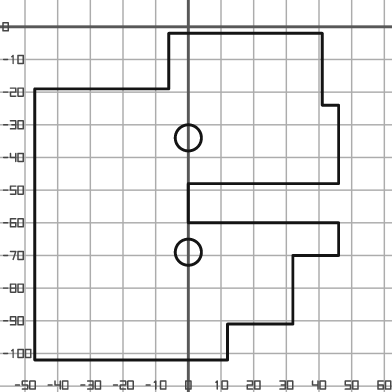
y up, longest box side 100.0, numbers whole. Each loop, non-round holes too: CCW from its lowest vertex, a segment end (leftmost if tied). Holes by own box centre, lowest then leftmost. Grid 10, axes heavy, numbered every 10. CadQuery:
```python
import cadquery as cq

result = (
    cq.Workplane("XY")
    .moveTo(-47.0, -102.0)
    .lineTo(12.0, -102.0)
    .lineTo(12.0, -91.0)
    .lineTo(32.0, -91.0)
    .lineTo(32.0, -70.0)
    .lineTo(46.0, -70.0)
    .lineTo(46.0, -60.0)
    .lineTo(0.0, -60.0)
    .lineTo(0.0, -48.0)
    .lineTo(46.0, -48.0)
    .lineTo(46.0, -24.0)
    .lineTo(41.0, -24.0)
    .lineTo(41.0, -2.0)
    .lineTo(-6.0, -2.0)
    .lineTo(-6.0, -19.0)
    .lineTo(-47.0, -19.0)
    .close()
    .moveTo(0.0, -69.0)
    .circle(4.0)
    .moveTo(0.0, -34.0)
    .circle(4.0)
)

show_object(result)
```